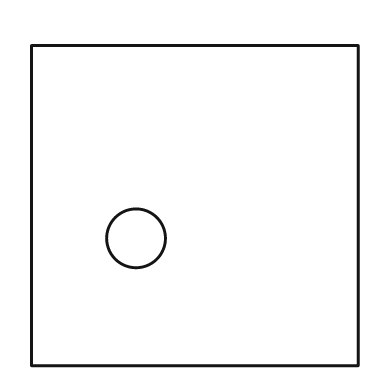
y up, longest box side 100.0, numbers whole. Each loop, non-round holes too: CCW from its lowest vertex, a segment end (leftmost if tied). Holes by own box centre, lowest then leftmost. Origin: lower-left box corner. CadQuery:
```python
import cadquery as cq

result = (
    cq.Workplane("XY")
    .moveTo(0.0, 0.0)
    .lineTo(100.0, 0.0)
    .lineTo(100.0, 98.0)
    .lineTo(0.0, 98.0)
    .close()
    .moveTo(32.0, 39.0)
    .circle(9.0)
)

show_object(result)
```